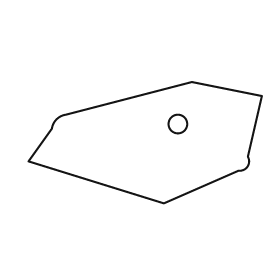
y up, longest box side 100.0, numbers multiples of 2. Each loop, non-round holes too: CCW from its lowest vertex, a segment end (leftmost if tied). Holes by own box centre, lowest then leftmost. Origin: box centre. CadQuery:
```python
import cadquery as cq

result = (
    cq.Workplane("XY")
    .moveTo(8.0, -26.0)
    .lineTo(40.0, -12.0)
    .threePointArc((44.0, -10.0), (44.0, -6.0))
    .lineTo(50.0, 20.0)
    .lineTo(20.0, 26.0)
    .lineTo(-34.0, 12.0)
    .threePointArc((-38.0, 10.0), (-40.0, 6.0))
    .lineTo(-50.0, -8.0)
    .close()
    .moveTo(14.0, 8.0)
    .circle(4.0)
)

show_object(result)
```